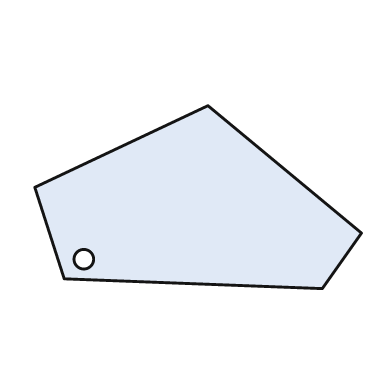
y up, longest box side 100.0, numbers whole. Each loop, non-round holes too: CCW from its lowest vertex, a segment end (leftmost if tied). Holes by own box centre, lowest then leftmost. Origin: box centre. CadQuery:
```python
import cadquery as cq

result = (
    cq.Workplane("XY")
    .moveTo(38.0, -28.0)
    .lineTo(50.0, -11.0)
    .lineTo(3.0, 28.0)
    .lineTo(-50.0, 3.0)
    .lineTo(-41.0, -25.0)
    .close()
    .moveTo(-35.0, -19.0)
    .circle(3.0)
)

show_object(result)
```